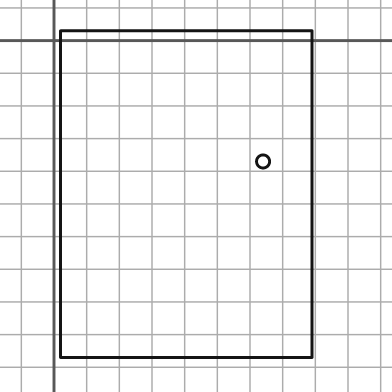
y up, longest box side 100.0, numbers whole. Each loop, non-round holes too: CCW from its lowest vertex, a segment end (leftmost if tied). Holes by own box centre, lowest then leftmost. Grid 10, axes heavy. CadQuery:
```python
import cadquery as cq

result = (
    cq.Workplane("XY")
    .moveTo(2.0, -97.0)
    .lineTo(79.0, -97.0)
    .lineTo(79.0, 3.0)
    .lineTo(2.0, 3.0)
    .close()
    .moveTo(64.0, -37.0)
    .circle(2.0)
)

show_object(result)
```